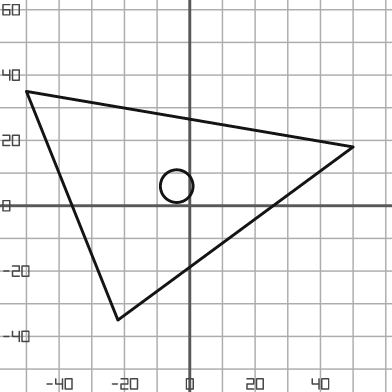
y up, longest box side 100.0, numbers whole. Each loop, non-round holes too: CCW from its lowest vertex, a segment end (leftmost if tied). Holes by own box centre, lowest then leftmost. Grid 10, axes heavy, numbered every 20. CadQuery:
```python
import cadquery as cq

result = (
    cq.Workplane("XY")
    .moveTo(-22.0, -35.0)
    .lineTo(50.0, 18.0)
    .lineTo(-50.0, 35.0)
    .close()
    .moveTo(-4.0, 6.0)
    .circle(5.0)
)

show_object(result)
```